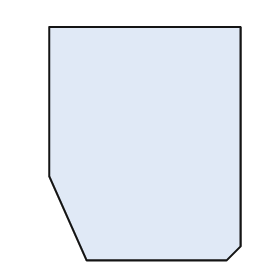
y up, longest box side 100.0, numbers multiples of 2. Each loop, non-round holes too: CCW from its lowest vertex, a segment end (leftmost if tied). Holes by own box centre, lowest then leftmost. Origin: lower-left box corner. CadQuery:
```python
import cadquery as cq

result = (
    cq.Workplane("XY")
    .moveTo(16.0, 0.0)
    .lineTo(76.0, 0.0)
    .lineTo(82.0, 6.0)
    .lineTo(82.0, 100.0)
    .lineTo(0.0, 100.0)
    .lineTo(0.0, 36.0)
    .close()
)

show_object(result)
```